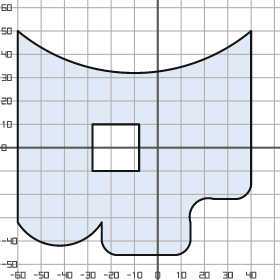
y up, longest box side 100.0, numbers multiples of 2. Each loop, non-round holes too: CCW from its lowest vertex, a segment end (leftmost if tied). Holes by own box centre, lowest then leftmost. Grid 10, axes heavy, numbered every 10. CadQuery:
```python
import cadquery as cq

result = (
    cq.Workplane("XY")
    .moveTo(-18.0, -46.0)
    .lineTo(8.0, -46.0)
    .threePointArc((12.0, -44.0), (14.0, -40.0))
    .lineTo(14.0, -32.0)
    .threePointArc((16.0, -24.0), (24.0, -22.0))
    .lineTo(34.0, -22.0)
    .threePointArc((38.0, -20.0), (40.0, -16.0))
    .lineTo(40.0, 50.0)
    .threePointArc((-10.0, 32.0), (-60.0, 50.0))
    .lineTo(-60.0, -32.0)
    .threePointArc((-42.0, -42.0), (-24.0, -32.0))
    .lineTo(-24.0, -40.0)
    .threePointArc((-22.0, -44.0), (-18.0, -46.0))
    .close()
    .moveTo(-28.0, -10.0)
    .lineTo(-8.0, -10.0)
    .lineTo(-8.0, 10.0)
    .lineTo(-28.0, 10.0)
    .close()
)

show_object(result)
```